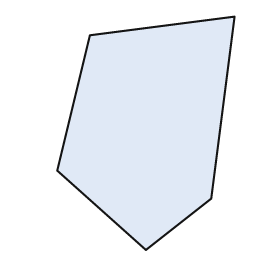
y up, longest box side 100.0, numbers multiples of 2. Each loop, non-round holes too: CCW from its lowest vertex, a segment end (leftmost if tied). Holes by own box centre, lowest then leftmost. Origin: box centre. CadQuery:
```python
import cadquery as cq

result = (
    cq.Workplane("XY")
    .moveTo(0.0, -50.0)
    .lineTo(28.0, -28.0)
    .lineTo(38.0, 50.0)
    .lineTo(-24.0, 42.0)
    .lineTo(-38.0, -16.0)
    .close()
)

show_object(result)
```